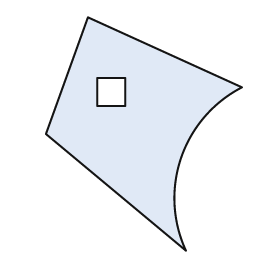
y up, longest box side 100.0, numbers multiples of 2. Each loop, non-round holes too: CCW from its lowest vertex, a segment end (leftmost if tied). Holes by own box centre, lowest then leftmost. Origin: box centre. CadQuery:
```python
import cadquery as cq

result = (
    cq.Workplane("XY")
    .moveTo(18.0, -50.0)
    .threePointArc((16.0, -10.0), (42.0, 20.0))
    .lineTo(-24.0, 50.0)
    .lineTo(-42.0, 0.0)
    .close()
    .moveTo(-20.0, 12.0)
    .lineTo(-8.0, 12.0)
    .lineTo(-8.0, 24.0)
    .lineTo(-20.0, 24.0)
    .close()
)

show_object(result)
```